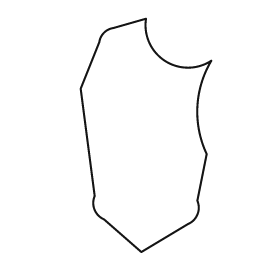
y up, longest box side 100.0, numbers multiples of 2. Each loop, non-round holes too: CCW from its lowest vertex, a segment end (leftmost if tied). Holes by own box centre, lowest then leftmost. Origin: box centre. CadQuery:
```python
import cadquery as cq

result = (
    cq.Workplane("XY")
    .moveTo(-2.0, -50.0)
    .lineTo(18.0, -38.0)
    .threePointArc((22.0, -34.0), (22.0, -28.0))
    .lineTo(26.0, -8.0)
    .threePointArc((22.0, 12.0), (28.0, 32.0))
    .threePointArc((8.0, 32.0), (0.0, 50.0))
    .lineTo(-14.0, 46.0)
    .threePointArc((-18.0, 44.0), (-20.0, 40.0))
    .lineTo(-28.0, 20.0)
    .lineTo(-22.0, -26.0)
    .threePointArc((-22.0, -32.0), (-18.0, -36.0))
    .close()
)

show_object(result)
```